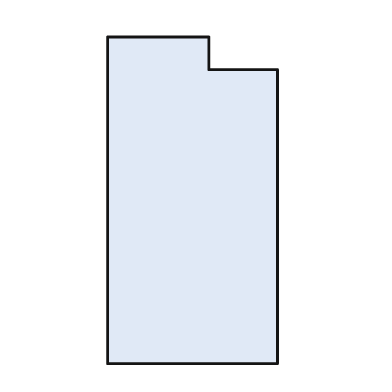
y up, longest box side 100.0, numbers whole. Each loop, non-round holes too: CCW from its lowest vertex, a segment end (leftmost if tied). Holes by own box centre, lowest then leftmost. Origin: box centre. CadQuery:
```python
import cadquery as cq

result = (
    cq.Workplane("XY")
    .moveTo(-26.0, -50.0)
    .lineTo(26.0, -50.0)
    .lineTo(26.0, 40.0)
    .lineTo(5.0, 40.0)
    .lineTo(5.0, 50.0)
    .lineTo(-26.0, 50.0)
    .close()
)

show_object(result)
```